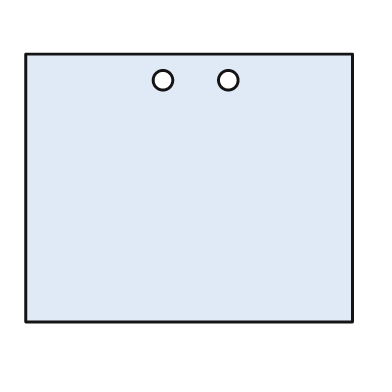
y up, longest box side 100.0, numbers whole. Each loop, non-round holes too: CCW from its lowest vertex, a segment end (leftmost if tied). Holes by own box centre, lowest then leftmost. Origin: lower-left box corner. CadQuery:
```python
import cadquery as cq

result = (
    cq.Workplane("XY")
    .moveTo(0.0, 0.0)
    .lineTo(100.0, 0.0)
    .lineTo(100.0, 82.0)
    .lineTo(0.0, 82.0)
    .close()
    .moveTo(42.0, 74.0)
    .circle(3.0)
    .moveTo(62.0, 74.0)
    .circle(3.0)
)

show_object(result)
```